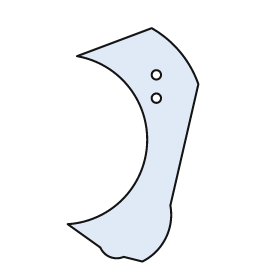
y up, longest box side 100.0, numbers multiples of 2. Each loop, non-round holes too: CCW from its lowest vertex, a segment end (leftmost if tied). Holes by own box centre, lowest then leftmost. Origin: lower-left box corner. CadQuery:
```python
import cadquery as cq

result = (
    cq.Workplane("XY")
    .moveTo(32.0, 0.0)
    .threePointArc((42.0, 10.0), (44.0, 24.0))
    .lineTo(56.0, 76.0)
    .threePointArc((48.0, 90.0), (36.0, 100.0))
    .lineTo(4.0, 88.0)
    .threePointArc((34.0, 50.0), (0.0, 16.0))
    .lineTo(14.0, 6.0)
    .threePointArc((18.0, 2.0), (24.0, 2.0))
    .close()
    .moveTo(38.0, 70.0)
    .circle(2.0)
    .moveTo(38.0, 80.0)
    .circle(2.0)
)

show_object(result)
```